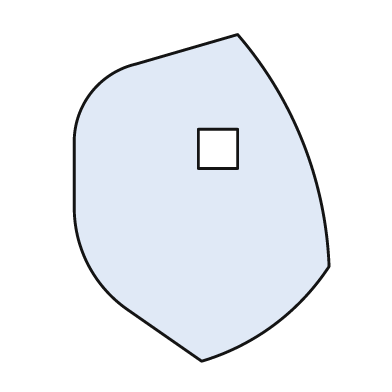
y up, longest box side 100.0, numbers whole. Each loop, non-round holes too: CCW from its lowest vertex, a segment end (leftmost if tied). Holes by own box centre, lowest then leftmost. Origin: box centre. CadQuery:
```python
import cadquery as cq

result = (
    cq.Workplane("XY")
    .moveTo(0.0, -50.0)
    .threePointArc((22.0, -39.0), (39.0, -21.0))
    .threePointArc((31.0, 17.0), (11.0, 50.0))
    .lineTo(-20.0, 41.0)
    .threePointArc((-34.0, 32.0), (-39.0, 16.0))
    .lineTo(-39.0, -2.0)
    .threePointArc((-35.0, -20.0), (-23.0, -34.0))
    .close()
    .moveTo(-1.0, 9.0)
    .lineTo(11.0, 9.0)
    .lineTo(11.0, 21.0)
    .lineTo(-1.0, 21.0)
    .close()
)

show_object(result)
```